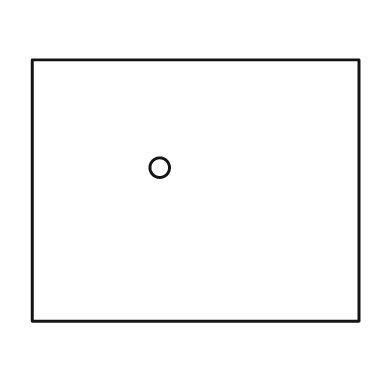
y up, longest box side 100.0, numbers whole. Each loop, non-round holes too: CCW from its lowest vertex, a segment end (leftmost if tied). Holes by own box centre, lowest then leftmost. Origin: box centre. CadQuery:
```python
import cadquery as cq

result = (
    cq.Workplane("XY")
    .moveTo(-50.0, -40.0)
    .lineTo(50.0, -40.0)
    .lineTo(50.0, 40.0)
    .lineTo(-50.0, 40.0)
    .close()
    .moveTo(-11.0, 7.0)
    .circle(3.0)
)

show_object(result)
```